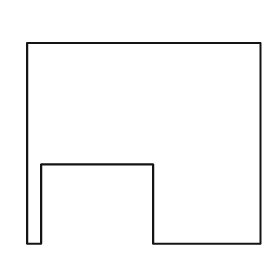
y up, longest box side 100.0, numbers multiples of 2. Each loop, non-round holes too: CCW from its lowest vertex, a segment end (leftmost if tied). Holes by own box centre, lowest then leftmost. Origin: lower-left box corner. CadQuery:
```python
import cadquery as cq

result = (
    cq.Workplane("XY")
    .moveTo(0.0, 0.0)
    .lineTo(6.0, 0.0)
    .lineTo(6.0, 34.0)
    .lineTo(54.0, 34.0)
    .lineTo(54.0, 0.0)
    .lineTo(100.0, 0.0)
    .lineTo(100.0, 86.0)
    .lineTo(0.0, 86.0)
    .close()
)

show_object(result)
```